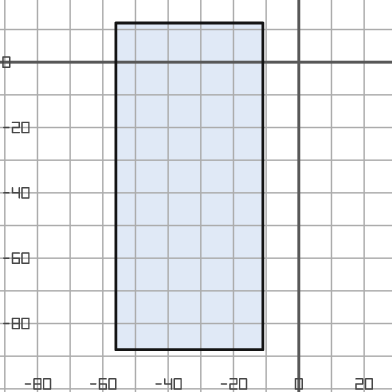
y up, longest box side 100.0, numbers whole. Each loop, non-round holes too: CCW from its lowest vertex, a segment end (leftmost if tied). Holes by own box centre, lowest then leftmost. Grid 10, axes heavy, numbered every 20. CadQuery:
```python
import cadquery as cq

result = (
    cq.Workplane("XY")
    .moveTo(-56.0, -88.0)
    .lineTo(-11.0, -88.0)
    .lineTo(-11.0, 12.0)
    .lineTo(-56.0, 12.0)
    .close()
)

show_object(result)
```